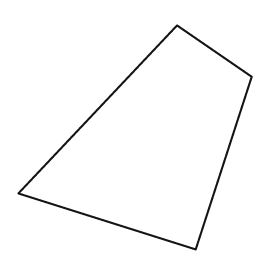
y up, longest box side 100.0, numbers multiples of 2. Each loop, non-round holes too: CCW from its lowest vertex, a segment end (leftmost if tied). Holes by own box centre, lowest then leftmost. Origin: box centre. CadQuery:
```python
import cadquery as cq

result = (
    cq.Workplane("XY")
    .moveTo(26.0, -48.0)
    .lineTo(50.0, 26.0)
    .lineTo(18.0, 48.0)
    .lineTo(-50.0, -24.0)
    .close()
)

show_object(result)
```